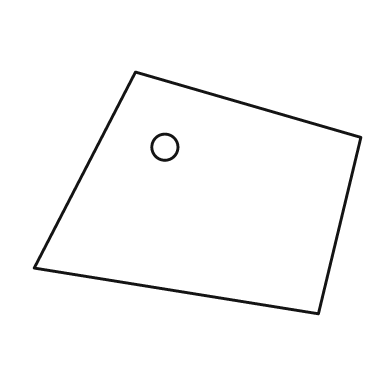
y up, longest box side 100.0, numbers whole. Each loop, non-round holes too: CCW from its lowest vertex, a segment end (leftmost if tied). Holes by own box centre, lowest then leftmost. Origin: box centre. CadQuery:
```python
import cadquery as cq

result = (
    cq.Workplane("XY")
    .moveTo(37.0, -37.0)
    .lineTo(50.0, 17.0)
    .lineTo(-19.0, 37.0)
    .lineTo(-50.0, -23.0)
    .close()
    .moveTo(-10.0, 14.0)
    .circle(4.0)
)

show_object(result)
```